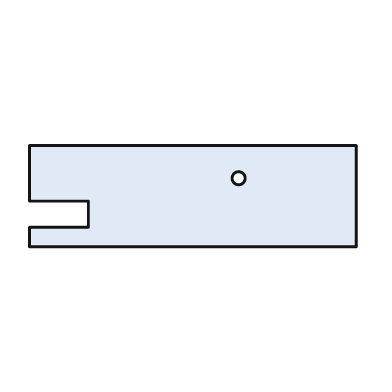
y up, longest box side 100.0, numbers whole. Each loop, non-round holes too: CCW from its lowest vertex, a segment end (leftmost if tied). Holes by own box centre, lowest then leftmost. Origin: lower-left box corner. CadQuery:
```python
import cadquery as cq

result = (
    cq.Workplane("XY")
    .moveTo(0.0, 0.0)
    .lineTo(100.0, 0.0)
    .lineTo(100.0, 31.0)
    .lineTo(0.0, 31.0)
    .lineTo(0.0, 14.0)
    .lineTo(18.0, 14.0)
    .lineTo(18.0, 6.0)
    .lineTo(0.0, 6.0)
    .close()
    .moveTo(64.0, 21.0)
    .circle(2.0)
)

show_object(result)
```